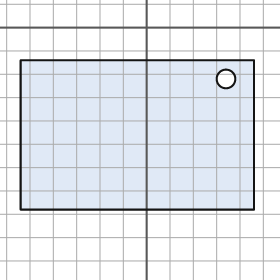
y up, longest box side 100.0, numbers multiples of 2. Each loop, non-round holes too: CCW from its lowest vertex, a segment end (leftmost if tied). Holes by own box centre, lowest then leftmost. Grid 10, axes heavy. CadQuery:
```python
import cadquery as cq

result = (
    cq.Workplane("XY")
    .moveTo(-54.0, -78.0)
    .lineTo(46.0, -78.0)
    .lineTo(46.0, -14.0)
    .lineTo(-54.0, -14.0)
    .close()
    .moveTo(34.0, -22.0)
    .circle(4.0)
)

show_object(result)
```